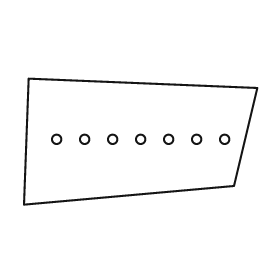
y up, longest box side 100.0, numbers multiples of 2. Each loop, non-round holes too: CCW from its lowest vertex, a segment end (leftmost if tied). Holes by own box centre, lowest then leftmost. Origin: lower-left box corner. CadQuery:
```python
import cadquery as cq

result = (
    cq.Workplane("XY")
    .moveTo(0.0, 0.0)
    .lineTo(90.0, 8.0)
    .lineTo(100.0, 50.0)
    .lineTo(2.0, 54.0)
    .close()
    .moveTo(14.0, 28.0)
    .circle(2.0)
    .moveTo(26.0, 28.0)
    .circle(2.0)
    .moveTo(38.0, 28.0)
    .circle(2.0)
    .moveTo(50.0, 28.0)
    .circle(2.0)
    .moveTo(62.0, 28.0)
    .circle(2.0)
    .moveTo(74.0, 28.0)
    .circle(2.0)
    .moveTo(86.0, 28.0)
    .circle(2.0)
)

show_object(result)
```